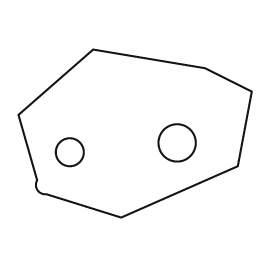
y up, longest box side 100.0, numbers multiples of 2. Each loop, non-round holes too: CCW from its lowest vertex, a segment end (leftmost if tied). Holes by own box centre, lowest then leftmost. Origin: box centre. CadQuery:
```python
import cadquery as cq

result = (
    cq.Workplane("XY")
    .moveTo(-6.0, -36.0)
    .lineTo(44.0, -14.0)
    .lineTo(50.0, 18.0)
    .lineTo(30.0, 28.0)
    .lineTo(-18.0, 36.0)
    .lineTo(-50.0, 8.0)
    .lineTo(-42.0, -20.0)
    .threePointArc((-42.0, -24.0), (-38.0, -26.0))
    .close()
    .moveTo(-28.0, -8.0)
    .circle(6.0)
    .moveTo(18.0, -4.0)
    .circle(8.0)
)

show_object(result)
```